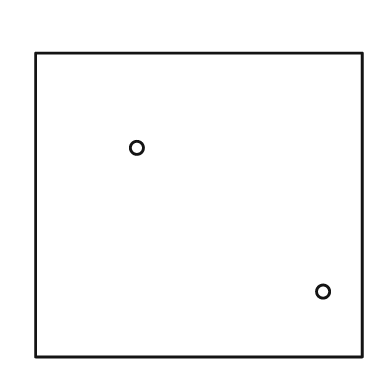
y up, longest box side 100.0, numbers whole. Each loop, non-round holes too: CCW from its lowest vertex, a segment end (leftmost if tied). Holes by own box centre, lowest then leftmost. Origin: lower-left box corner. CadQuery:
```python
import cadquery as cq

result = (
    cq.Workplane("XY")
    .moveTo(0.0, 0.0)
    .lineTo(100.0, 0.0)
    .lineTo(100.0, 93.0)
    .lineTo(0.0, 93.0)
    .close()
    .moveTo(88.0, 20.0)
    .circle(2.0)
    .moveTo(31.0, 64.0)
    .circle(2.0)
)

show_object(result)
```